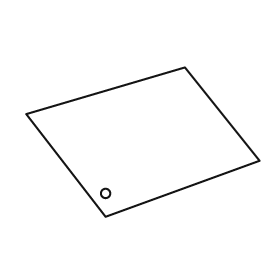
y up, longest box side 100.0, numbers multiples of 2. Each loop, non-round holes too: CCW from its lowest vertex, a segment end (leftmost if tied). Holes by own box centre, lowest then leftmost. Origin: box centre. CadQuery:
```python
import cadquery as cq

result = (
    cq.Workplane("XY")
    .moveTo(-16.0, -32.0)
    .lineTo(50.0, -8.0)
    .lineTo(18.0, 32.0)
    .lineTo(-50.0, 12.0)
    .close()
    .moveTo(-16.0, -22.0)
    .circle(2.0)
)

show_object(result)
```